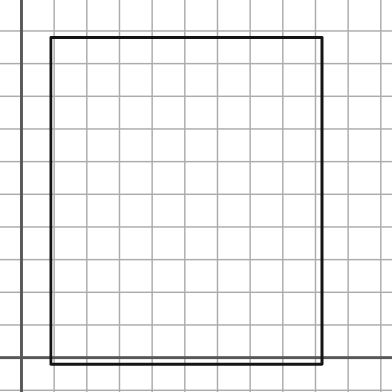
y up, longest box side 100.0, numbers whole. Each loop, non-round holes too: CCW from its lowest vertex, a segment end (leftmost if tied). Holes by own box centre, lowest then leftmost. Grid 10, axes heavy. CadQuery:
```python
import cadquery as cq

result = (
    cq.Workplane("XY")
    .moveTo(9.0, -2.0)
    .lineTo(92.0, -2.0)
    .lineTo(92.0, 98.0)
    .lineTo(9.0, 98.0)
    .close()
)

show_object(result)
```